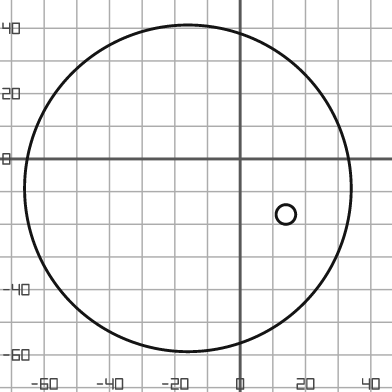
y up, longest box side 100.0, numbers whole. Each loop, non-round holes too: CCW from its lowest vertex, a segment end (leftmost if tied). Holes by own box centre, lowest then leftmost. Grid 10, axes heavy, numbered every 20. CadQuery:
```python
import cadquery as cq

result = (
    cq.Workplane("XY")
    .moveTo(-16.0, -9.0)
    .circle(50.0)
    .moveTo(14.0, -17.0)
    .circle(3.0)
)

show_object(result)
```